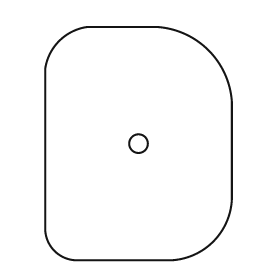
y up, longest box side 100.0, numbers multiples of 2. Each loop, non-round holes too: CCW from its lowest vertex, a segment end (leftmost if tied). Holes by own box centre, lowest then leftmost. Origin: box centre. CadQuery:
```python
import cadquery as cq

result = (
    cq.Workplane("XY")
    .moveTo(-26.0, -50.0)
    .lineTo(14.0, -50.0)
    .threePointArc((32.0, -42.0), (40.0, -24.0))
    .lineTo(40.0, 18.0)
    .threePointArc((30.0, 40.0), (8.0, 50.0))
    .lineTo(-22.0, 50.0)
    .threePointArc((-34.0, 44.0), (-40.0, 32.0))
    .lineTo(-40.0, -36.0)
    .threePointArc((-36.0, -46.0), (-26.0, -50.0))
    .close()
    .moveTo(0.0, 0.0)
    .circle(4.0)
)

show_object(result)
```